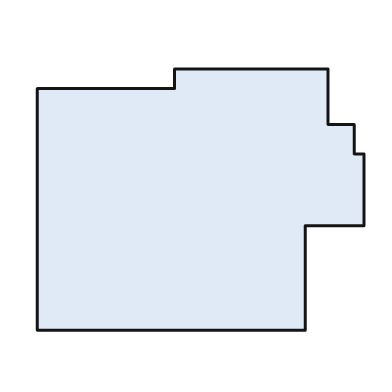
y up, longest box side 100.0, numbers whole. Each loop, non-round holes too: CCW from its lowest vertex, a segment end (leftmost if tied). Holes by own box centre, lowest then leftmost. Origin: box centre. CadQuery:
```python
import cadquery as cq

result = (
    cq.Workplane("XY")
    .moveTo(-50.0, -40.0)
    .lineTo(32.0, -40.0)
    .lineTo(32.0, -8.0)
    .lineTo(50.0, -8.0)
    .lineTo(50.0, 14.0)
    .lineTo(47.0, 14.0)
    .lineTo(47.0, 23.0)
    .lineTo(39.0, 23.0)
    .lineTo(39.0, 40.0)
    .lineTo(-8.0, 40.0)
    .lineTo(-8.0, 34.0)
    .lineTo(-50.0, 34.0)
    .close()
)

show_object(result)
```